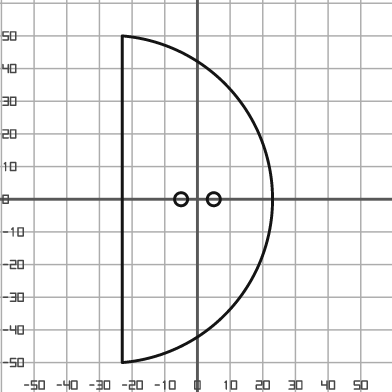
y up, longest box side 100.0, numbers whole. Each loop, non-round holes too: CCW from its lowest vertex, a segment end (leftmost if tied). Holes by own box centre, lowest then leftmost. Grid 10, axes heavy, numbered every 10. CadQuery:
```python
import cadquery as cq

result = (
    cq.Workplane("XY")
    .moveTo(-23.0, -50.0)
    .threePointArc((23.0, 0.0), (-23.0, 50.0))
    .close()
    .moveTo(-5.0, 0.0)
    .circle(2.0)
    .moveTo(5.0, 0.0)
    .circle(2.0)
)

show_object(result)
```